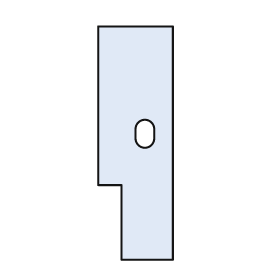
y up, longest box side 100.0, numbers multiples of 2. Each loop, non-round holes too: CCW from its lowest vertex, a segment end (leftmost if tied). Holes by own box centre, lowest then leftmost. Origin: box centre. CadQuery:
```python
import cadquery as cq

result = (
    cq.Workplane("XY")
    .moveTo(-6.0, -50.0)
    .lineTo(16.0, -50.0)
    .lineTo(16.0, 50.0)
    .lineTo(-16.0, 50.0)
    .lineTo(-16.0, -18.0)
    .lineTo(-6.0, -18.0)
    .close()
    .moveTo(0.0, 2.0)
    .threePointArc((4.0, -2.0), (8.0, 2.0))
    .lineTo(8.0, 6.0)
    .threePointArc((4.0, 10.0), (0.0, 6.0))
    .close()
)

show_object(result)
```